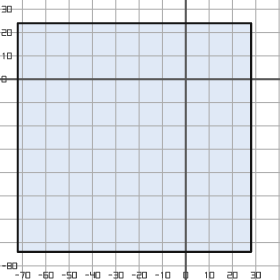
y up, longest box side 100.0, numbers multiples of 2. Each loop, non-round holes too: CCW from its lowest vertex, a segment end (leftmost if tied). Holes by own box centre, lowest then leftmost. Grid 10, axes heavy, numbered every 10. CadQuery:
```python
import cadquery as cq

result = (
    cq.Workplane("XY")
    .moveTo(-72.0, -74.0)
    .lineTo(28.0, -74.0)
    .lineTo(28.0, 24.0)
    .lineTo(-72.0, 24.0)
    .close()
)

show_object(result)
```